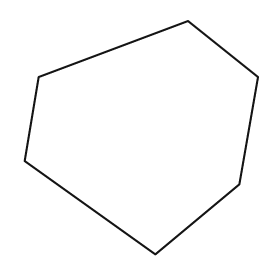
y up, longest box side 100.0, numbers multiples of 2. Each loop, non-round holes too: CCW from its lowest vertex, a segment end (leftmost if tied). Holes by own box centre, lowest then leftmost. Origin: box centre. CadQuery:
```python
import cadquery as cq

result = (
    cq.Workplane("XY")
    .moveTo(6.0, -50.0)
    .lineTo(42.0, -20.0)
    .lineTo(50.0, 26.0)
    .lineTo(20.0, 50.0)
    .lineTo(-44.0, 26.0)
    .lineTo(-50.0, -10.0)
    .close()
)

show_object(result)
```